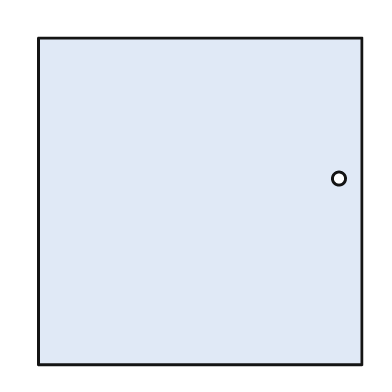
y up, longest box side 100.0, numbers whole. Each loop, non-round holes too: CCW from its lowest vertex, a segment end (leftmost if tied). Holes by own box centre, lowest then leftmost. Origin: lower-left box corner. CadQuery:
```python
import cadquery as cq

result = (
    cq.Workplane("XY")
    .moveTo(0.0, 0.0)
    .lineTo(99.0, 0.0)
    .lineTo(99.0, 100.0)
    .lineTo(0.0, 100.0)
    .close()
    .moveTo(92.0, 57.0)
    .circle(2.0)
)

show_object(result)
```